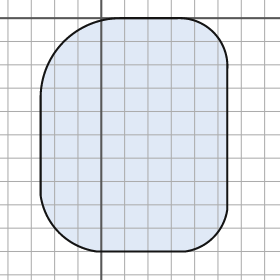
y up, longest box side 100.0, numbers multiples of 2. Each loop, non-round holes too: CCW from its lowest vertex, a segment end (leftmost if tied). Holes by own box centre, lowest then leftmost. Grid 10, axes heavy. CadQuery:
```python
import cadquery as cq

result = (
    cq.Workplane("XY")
    .moveTo(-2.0, -100.0)
    .lineTo(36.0, -100.0)
    .threePointArc((48.0, -94.0), (54.0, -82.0))
    .lineTo(54.0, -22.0)
    .threePointArc((48.0, -6.0), (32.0, 0.0))
    .lineTo(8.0, 0.0)
    .threePointArc((-16.0, -10.0), (-26.0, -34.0))
    .lineTo(-26.0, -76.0)
    .threePointArc((-18.0, -92.0), (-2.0, -100.0))
    .close()
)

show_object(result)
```